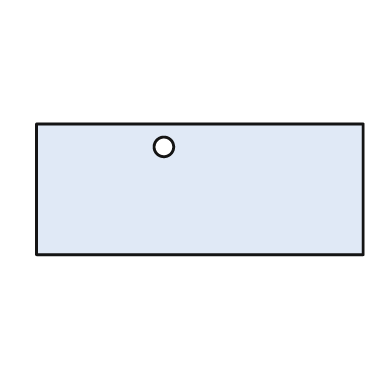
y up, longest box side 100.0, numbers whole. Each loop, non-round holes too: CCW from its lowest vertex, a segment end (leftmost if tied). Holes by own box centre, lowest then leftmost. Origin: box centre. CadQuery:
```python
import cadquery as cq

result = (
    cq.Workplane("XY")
    .moveTo(-50.0, -20.0)
    .lineTo(50.0, -20.0)
    .lineTo(50.0, 20.0)
    .lineTo(-50.0, 20.0)
    .close()
    .moveTo(-11.0, 13.0)
    .circle(3.0)
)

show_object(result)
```